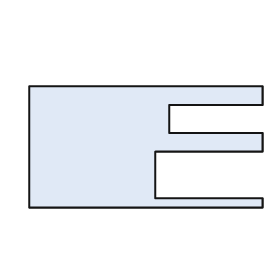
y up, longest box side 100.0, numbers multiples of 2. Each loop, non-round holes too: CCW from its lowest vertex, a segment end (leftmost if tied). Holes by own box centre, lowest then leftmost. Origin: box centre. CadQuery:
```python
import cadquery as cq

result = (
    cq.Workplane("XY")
    .moveTo(-50.0, -26.0)
    .lineTo(50.0, -26.0)
    .lineTo(50.0, -22.0)
    .lineTo(4.0, -22.0)
    .lineTo(4.0, -2.0)
    .lineTo(50.0, -2.0)
    .lineTo(50.0, 6.0)
    .lineTo(10.0, 6.0)
    .lineTo(10.0, 18.0)
    .lineTo(50.0, 18.0)
    .lineTo(50.0, 26.0)
    .lineTo(-50.0, 26.0)
    .close()
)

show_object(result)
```